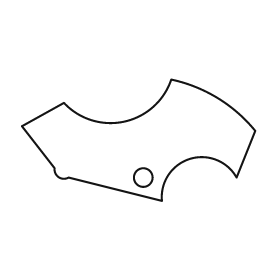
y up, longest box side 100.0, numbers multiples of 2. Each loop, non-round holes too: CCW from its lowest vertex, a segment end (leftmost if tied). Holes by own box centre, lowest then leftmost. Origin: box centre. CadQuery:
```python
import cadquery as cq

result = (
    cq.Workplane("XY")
    .moveTo(10.0, -26.0)
    .threePointArc((22.0, -8.0), (42.0, -16.0))
    .lineTo(50.0, 4.0)
    .threePointArc((34.0, 18.0), (14.0, 26.0))
    .threePointArc((-6.0, 8.0), (-32.0, 16.0))
    .lineTo(-50.0, 6.0)
    .lineTo(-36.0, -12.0)
    .threePointArc((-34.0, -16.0), (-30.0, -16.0))
    .close()
    .moveTo(2.0, -16.0)
    .circle(4.0)
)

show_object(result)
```